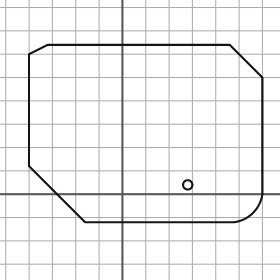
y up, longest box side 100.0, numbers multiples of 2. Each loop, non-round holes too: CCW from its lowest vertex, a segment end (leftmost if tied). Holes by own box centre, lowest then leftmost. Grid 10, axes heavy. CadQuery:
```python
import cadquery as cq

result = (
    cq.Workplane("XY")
    .moveTo(-16.0, -12.0)
    .lineTo(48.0, -12.0)
    .threePointArc((56.0, -8.0), (60.0, 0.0))
    .lineTo(60.0, 50.0)
    .lineTo(46.0, 64.0)
    .lineTo(-32.0, 64.0)
    .lineTo(-40.0, 60.0)
    .lineTo(-40.0, 12.0)
    .close()
    .moveTo(28.0, 4.0)
    .circle(2.0)
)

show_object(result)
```